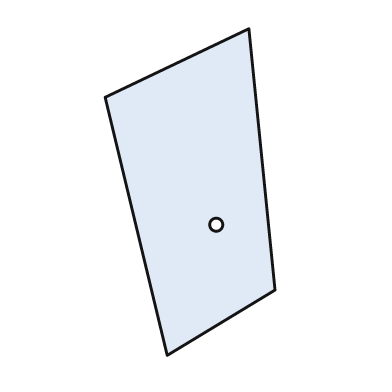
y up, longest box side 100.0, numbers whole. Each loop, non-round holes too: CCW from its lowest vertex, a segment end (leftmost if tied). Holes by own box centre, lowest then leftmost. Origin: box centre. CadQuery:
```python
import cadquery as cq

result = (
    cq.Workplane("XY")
    .moveTo(-7.0, -50.0)
    .lineTo(26.0, -30.0)
    .lineTo(18.0, 50.0)
    .lineTo(-26.0, 29.0)
    .close()
    .moveTo(8.0, -10.0)
    .circle(2.0)
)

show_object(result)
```